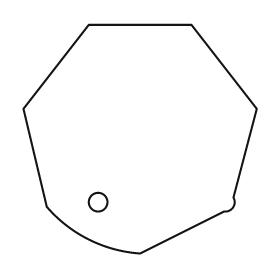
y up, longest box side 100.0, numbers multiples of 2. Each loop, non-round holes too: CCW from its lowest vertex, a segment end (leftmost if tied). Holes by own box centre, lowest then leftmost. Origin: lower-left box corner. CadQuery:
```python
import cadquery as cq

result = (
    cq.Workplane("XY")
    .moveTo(50.0, 0.0)
    .lineTo(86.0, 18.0)
    .threePointArc((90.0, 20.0), (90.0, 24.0))
    .lineTo(100.0, 62.0)
    .lineTo(72.0, 98.0)
    .lineTo(28.0, 98.0)
    .lineTo(0.0, 62.0)
    .lineTo(10.0, 20.0)
    .threePointArc((28.0, 6.0), (50.0, 0.0))
    .close()
    .moveTo(32.0, 22.0)
    .circle(4.0)
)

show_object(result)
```